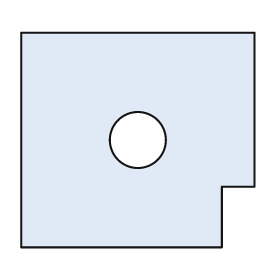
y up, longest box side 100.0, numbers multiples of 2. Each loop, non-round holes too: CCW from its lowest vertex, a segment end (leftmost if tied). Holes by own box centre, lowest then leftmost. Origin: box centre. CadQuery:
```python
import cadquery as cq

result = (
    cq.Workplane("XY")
    .moveTo(-50.0, -46.0)
    .lineTo(36.0, -46.0)
    .lineTo(36.0, -20.0)
    .lineTo(50.0, -20.0)
    .lineTo(50.0, 46.0)
    .lineTo(-50.0, 46.0)
    .close()
    .moveTo(0.0, 0.0)
    .circle(12.0)
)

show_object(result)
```